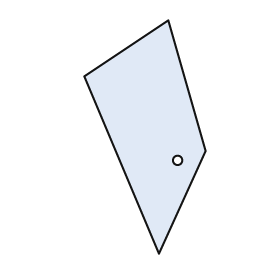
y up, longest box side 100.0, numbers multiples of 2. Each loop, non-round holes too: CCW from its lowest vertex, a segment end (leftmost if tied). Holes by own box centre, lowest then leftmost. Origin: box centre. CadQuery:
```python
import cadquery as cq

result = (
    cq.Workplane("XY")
    .moveTo(6.0, -50.0)
    .lineTo(26.0, -6.0)
    .lineTo(10.0, 50.0)
    .lineTo(-26.0, 26.0)
    .close()
    .moveTo(14.0, -10.0)
    .circle(2.0)
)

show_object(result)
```